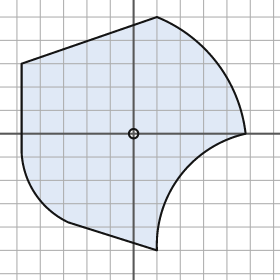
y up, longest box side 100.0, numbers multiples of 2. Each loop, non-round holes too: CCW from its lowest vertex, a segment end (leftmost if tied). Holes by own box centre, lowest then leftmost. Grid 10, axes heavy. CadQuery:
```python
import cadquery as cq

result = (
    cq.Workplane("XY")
    .moveTo(10.0, -50.0)
    .threePointArc((20.0, -18.0), (48.0, 0.0))
    .threePointArc((36.0, 30.0), (10.0, 50.0))
    .lineTo(-48.0, 30.0)
    .lineTo(-48.0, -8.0)
    .threePointArc((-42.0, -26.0), (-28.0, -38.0))
    .close()
    .moveTo(0.0, 0.0)
    .circle(2.0)
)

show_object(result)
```